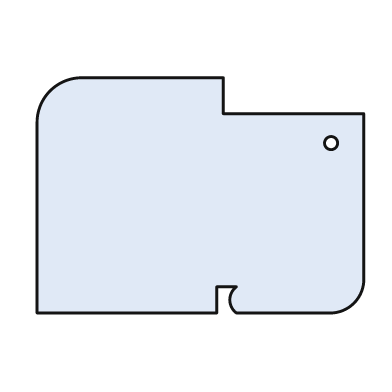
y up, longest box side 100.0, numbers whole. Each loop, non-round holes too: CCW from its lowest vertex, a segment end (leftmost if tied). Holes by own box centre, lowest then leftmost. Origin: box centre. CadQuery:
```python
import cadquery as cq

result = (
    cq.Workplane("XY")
    .moveTo(-50.0, -36.0)
    .lineTo(5.0, -36.0)
    .lineTo(5.0, -28.0)
    .lineTo(11.0, -28.0)
    .threePointArc((9.0, -32.0), (11.0, -36.0))
    .lineTo(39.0, -36.0)
    .threePointArc((47.0, -33.0), (50.0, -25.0))
    .lineTo(50.0, 25.0)
    .lineTo(7.0, 25.0)
    .lineTo(7.0, 36.0)
    .lineTo(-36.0, 36.0)
    .threePointArc((-46.0, 32.0), (-50.0, 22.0))
    .close()
    .moveTo(40.0, 16.0)
    .circle(2.0)
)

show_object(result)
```